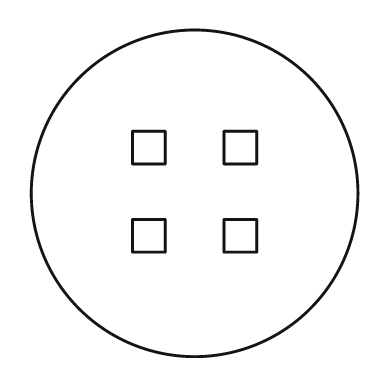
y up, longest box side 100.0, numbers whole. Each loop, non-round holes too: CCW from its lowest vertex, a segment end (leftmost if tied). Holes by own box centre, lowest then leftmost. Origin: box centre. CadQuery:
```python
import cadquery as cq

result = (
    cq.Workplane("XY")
    .moveTo(0.0, 0.0)
    .circle(50.0)
    .moveTo(-19.0, -18.0)
    .lineTo(-9.0, -18.0)
    .lineTo(-9.0, -8.0)
    .lineTo(-19.0, -8.0)
    .close()
    .moveTo(9.0, -18.0)
    .lineTo(19.0, -18.0)
    .lineTo(19.0, -8.0)
    .lineTo(9.0, -8.0)
    .close()
    .moveTo(-19.0, 9.0)
    .lineTo(-9.0, 9.0)
    .lineTo(-9.0, 19.0)
    .lineTo(-19.0, 19.0)
    .close()
    .moveTo(9.0, 9.0)
    .lineTo(19.0, 9.0)
    .lineTo(19.0, 19.0)
    .lineTo(9.0, 19.0)
    .close()
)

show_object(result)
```